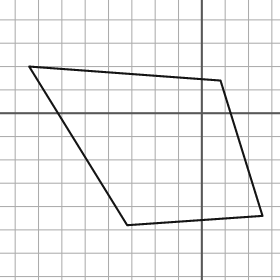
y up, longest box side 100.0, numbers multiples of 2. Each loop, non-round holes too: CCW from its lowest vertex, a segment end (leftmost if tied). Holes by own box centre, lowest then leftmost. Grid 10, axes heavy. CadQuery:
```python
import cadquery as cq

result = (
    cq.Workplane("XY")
    .moveTo(-32.0, -48.0)
    .lineTo(26.0, -44.0)
    .lineTo(8.0, 14.0)
    .lineTo(-74.0, 20.0)
    .close()
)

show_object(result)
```